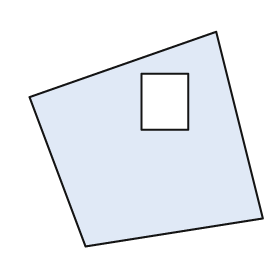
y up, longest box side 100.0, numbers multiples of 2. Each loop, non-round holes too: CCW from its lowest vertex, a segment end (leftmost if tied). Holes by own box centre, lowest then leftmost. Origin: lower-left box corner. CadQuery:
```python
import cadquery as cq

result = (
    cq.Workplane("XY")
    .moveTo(24.0, 0.0)
    .lineTo(100.0, 12.0)
    .lineTo(80.0, 92.0)
    .lineTo(0.0, 64.0)
    .close()
    .moveTo(48.0, 50.0)
    .lineTo(68.0, 50.0)
    .lineTo(68.0, 74.0)
    .lineTo(48.0, 74.0)
    .close()
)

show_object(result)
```